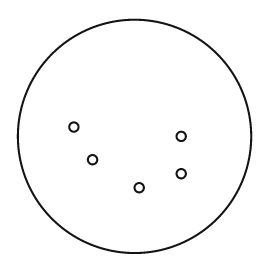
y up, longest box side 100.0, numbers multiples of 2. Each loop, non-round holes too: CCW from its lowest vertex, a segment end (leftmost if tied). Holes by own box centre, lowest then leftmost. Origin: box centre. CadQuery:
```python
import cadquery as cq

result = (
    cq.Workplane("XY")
    .moveTo(0.0, 0.0)
    .circle(50.0)
    .moveTo(2.0, -22.0)
    .circle(2.0)
    .moveTo(20.0, -16.0)
    .circle(2.0)
    .moveTo(-18.0, -10.0)
    .circle(2.0)
    .moveTo(20.0, 0.0)
    .circle(2.0)
    .moveTo(-26.0, 4.0)
    .circle(2.0)
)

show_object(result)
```